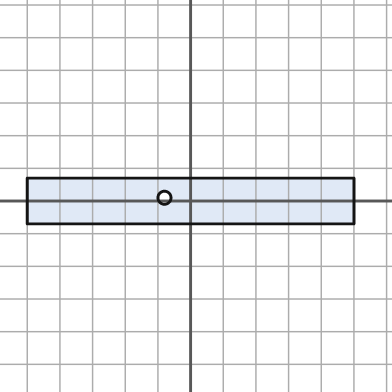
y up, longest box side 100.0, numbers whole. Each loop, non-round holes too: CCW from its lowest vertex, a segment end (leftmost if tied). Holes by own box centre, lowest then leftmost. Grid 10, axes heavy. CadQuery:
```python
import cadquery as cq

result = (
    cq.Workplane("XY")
    .moveTo(-50.0, -7.0)
    .lineTo(50.0, -7.0)
    .lineTo(50.0, 7.0)
    .lineTo(-50.0, 7.0)
    .close()
    .moveTo(-8.0, 1.0)
    .circle(2.0)
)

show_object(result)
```